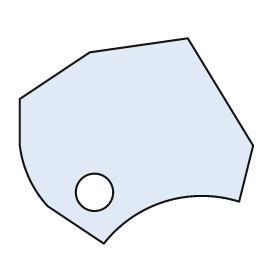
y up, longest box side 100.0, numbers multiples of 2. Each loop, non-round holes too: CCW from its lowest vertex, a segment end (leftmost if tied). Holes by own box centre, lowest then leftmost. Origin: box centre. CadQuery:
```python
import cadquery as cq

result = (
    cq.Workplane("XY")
    .moveTo(-14.0, -44.0)
    .threePointArc((12.0, -26.0), (44.0, -26.0))
    .lineTo(50.0, -2.0)
    .lineTo(22.0, 44.0)
    .lineTo(-20.0, 38.0)
    .lineTo(-50.0, 18.0)
    .lineTo(-50.0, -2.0)
    .threePointArc((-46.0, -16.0), (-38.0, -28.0))
    .close()
    .moveTo(-18.0, -22.0)
    .circle(8.0)
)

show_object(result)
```